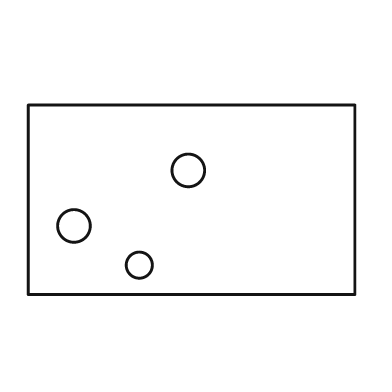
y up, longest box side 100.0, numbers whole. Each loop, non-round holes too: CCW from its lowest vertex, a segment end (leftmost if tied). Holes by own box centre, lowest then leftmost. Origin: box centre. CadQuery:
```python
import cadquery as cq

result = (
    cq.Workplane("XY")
    .moveTo(-50.0, -29.0)
    .lineTo(50.0, -29.0)
    .lineTo(50.0, 29.0)
    .lineTo(-50.0, 29.0)
    .close()
    .moveTo(-16.0, -20.0)
    .circle(4.0)
    .moveTo(-36.0, -8.0)
    .circle(5.0)
    .moveTo(-1.0, 9.0)
    .circle(5.0)
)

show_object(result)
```